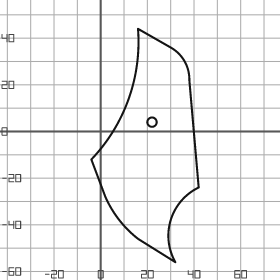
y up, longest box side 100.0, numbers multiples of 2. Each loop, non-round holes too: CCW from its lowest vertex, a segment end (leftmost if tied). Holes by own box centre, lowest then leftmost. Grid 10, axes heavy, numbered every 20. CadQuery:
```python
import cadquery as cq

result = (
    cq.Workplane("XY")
    .moveTo(32.0, -56.0)
    .threePointArc((30.0, -38.0), (42.0, -24.0))
    .lineTo(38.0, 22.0)
    .threePointArc((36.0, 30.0), (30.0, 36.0))
    .lineTo(16.0, 44.0)
    .threePointArc((12.0, 14.0), (-4.0, -12.0))
    .lineTo(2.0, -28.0)
    .threePointArc((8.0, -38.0), (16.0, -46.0))
    .close()
    .moveTo(22.0, 4.0)
    .circle(2.0)
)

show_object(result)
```